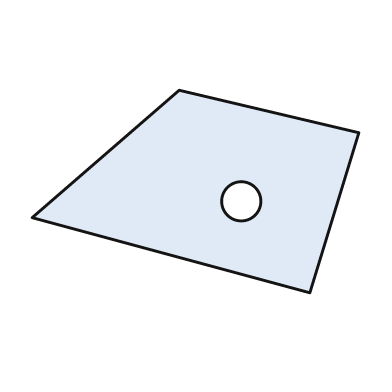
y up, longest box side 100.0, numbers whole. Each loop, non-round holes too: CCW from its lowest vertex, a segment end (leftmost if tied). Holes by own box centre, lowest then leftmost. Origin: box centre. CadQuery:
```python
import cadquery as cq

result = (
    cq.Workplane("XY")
    .moveTo(35.0, -31.0)
    .lineTo(50.0, 18.0)
    .lineTo(-5.0, 31.0)
    .lineTo(-50.0, -8.0)
    .close()
    .moveTo(14.0, -3.0)
    .circle(6.0)
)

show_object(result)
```